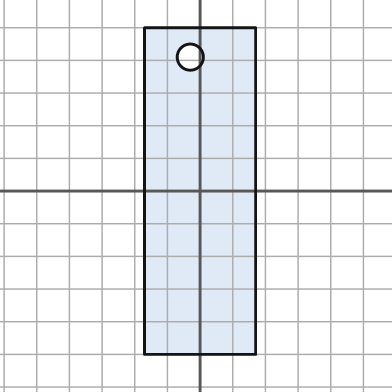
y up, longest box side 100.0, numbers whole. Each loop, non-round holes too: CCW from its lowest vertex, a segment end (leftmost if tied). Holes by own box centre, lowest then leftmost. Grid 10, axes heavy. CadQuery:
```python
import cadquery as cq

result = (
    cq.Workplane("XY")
    .moveTo(-17.0, -50.0)
    .lineTo(17.0, -50.0)
    .lineTo(17.0, 50.0)
    .lineTo(-17.0, 50.0)
    .close()
    .moveTo(-3.0, 41.0)
    .circle(4.0)
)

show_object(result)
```